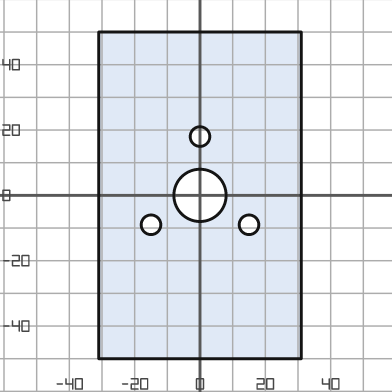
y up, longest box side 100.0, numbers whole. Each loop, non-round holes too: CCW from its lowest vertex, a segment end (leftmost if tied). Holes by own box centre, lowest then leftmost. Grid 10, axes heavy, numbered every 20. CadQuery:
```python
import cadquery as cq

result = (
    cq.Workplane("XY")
    .moveTo(-31.0, -50.0)
    .lineTo(31.0, -50.0)
    .lineTo(31.0, 50.0)
    .lineTo(-31.0, 50.0)
    .close()
    .moveTo(-15.0, -9.0)
    .circle(3.0)
    .moveTo(15.0, -9.0)
    .circle(3.0)
    .moveTo(0.0, 0.0)
    .circle(8.0)
    .moveTo(0.0, 18.0)
    .circle(3.0)
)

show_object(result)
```